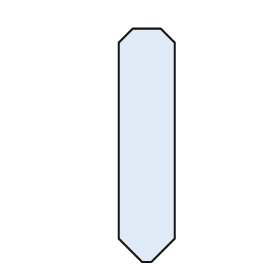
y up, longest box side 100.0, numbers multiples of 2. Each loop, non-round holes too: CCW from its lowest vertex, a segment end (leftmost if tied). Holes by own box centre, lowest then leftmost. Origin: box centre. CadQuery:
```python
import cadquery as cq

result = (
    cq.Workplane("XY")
    .moveTo(-2.0, -50.0)
    .lineTo(2.0, -50.0)
    .lineTo(12.0, -40.0)
    .lineTo(12.0, 44.0)
    .lineTo(6.0, 50.0)
    .lineTo(-6.0, 50.0)
    .lineTo(-12.0, 44.0)
    .lineTo(-12.0, -40.0)
    .close()
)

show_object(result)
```